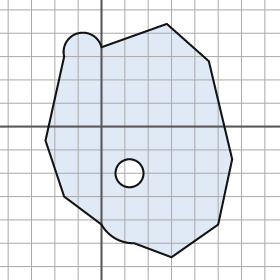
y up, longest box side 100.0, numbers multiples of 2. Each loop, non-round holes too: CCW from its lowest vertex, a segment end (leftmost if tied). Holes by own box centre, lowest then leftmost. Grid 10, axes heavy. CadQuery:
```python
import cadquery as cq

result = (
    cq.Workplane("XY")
    .moveTo(30.0, -56.0)
    .lineTo(50.0, -42.0)
    .lineTo(56.0, -14.0)
    .lineTo(46.0, 28.0)
    .lineTo(28.0, 44.0)
    .lineTo(0.0, 34.0)
    .threePointArc((-10.0, 40.0), (-16.0, 30.0))
    .lineTo(-24.0, -6.0)
    .lineTo(-16.0, -30.0)
    .lineTo(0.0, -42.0)
    .threePointArc((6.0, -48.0), (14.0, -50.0))
    .close()
    .moveTo(12.0, -20.0)
    .circle(6.0)
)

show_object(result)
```